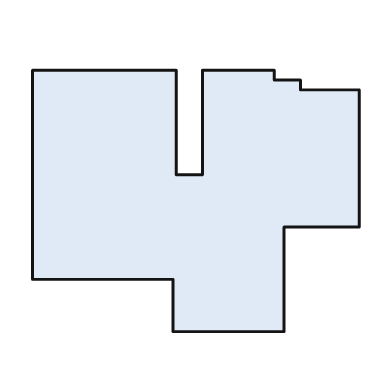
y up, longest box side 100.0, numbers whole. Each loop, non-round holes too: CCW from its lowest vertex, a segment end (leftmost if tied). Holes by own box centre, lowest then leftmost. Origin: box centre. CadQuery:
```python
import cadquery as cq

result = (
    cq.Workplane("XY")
    .moveTo(-7.0, -40.0)
    .lineTo(27.0, -40.0)
    .lineTo(27.0, -8.0)
    .lineTo(50.0, -8.0)
    .lineTo(50.0, 34.0)
    .lineTo(32.0, 34.0)
    .lineTo(32.0, 37.0)
    .lineTo(24.0, 37.0)
    .lineTo(24.0, 40.0)
    .lineTo(2.0, 40.0)
    .lineTo(2.0, 8.0)
    .lineTo(-6.0, 8.0)
    .lineTo(-6.0, 40.0)
    .lineTo(-50.0, 40.0)
    .lineTo(-50.0, -24.0)
    .lineTo(-7.0, -24.0)
    .close()
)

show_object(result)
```